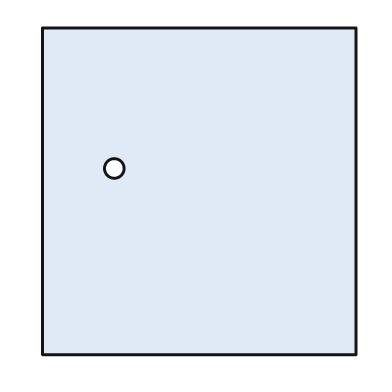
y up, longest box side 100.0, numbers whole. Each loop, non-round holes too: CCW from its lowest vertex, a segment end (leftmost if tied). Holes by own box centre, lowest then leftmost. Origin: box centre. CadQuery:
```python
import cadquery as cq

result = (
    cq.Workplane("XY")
    .moveTo(-48.0, -50.0)
    .lineTo(48.0, -50.0)
    .lineTo(48.0, 50.0)
    .lineTo(-48.0, 50.0)
    .close()
    .moveTo(-26.0, 7.0)
    .circle(3.0)
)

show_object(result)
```